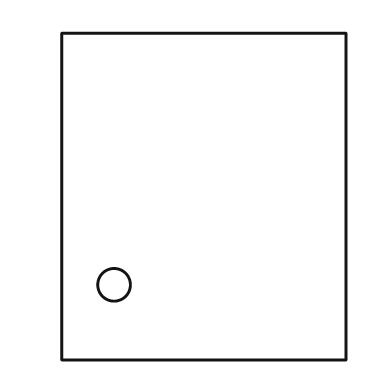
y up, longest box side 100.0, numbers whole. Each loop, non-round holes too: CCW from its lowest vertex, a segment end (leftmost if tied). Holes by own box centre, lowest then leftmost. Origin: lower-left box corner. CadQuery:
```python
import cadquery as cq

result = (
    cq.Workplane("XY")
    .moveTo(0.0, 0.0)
    .lineTo(87.0, 0.0)
    .lineTo(87.0, 100.0)
    .lineTo(0.0, 100.0)
    .close()
    .moveTo(16.0, 23.0)
    .circle(5.0)
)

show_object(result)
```